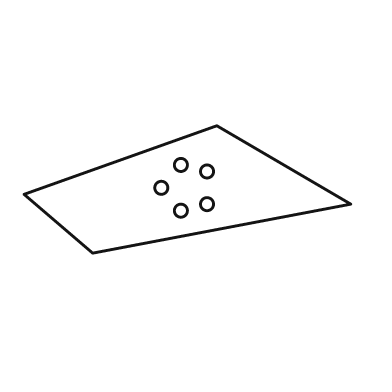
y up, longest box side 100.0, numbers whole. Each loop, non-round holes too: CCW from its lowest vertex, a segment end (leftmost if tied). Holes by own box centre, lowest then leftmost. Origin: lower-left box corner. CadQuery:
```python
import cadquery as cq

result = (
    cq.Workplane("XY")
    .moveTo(21.0, 0.0)
    .lineTo(100.0, 15.0)
    .lineTo(59.0, 39.0)
    .lineTo(0.0, 18.0)
    .close()
    .moveTo(48.0, 13.0)
    .circle(2.0)
    .moveTo(56.0, 15.0)
    .circle(2.0)
    .moveTo(42.0, 20.0)
    .circle(2.0)
    .moveTo(56.0, 25.0)
    .circle(2.0)
    .moveTo(48.0, 27.0)
    .circle(2.0)
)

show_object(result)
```